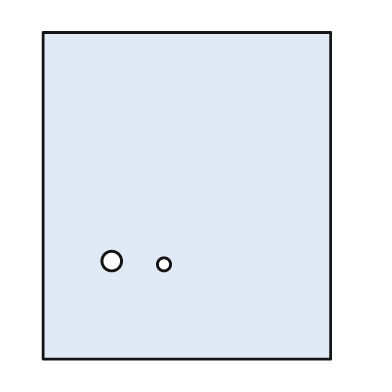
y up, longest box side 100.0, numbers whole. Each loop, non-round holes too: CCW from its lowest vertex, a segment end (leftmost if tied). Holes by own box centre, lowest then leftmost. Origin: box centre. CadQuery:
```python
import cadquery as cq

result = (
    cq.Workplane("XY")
    .moveTo(-44.0, -50.0)
    .lineTo(44.0, -50.0)
    .lineTo(44.0, 50.0)
    .lineTo(-44.0, 50.0)
    .close()
    .moveTo(-7.0, -21.0)
    .circle(2.0)
    .moveTo(-23.0, -20.0)
    .circle(3.0)
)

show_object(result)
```